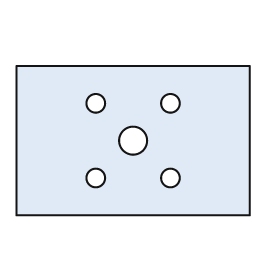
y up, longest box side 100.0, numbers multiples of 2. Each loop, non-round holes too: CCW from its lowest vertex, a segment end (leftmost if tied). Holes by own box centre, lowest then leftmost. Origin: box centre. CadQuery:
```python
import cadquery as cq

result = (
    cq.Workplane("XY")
    .moveTo(-50.0, -32.0)
    .lineTo(50.0, -32.0)
    .lineTo(50.0, 32.0)
    .lineTo(-50.0, 32.0)
    .close()
    .moveTo(-16.0, -16.0)
    .circle(4.0)
    .moveTo(16.0, -16.0)
    .circle(4.0)
    .moveTo(0.0, 0.0)
    .circle(6.0)
    .moveTo(-16.0, 16.0)
    .circle(4.0)
    .moveTo(16.0, 16.0)
    .circle(4.0)
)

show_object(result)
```